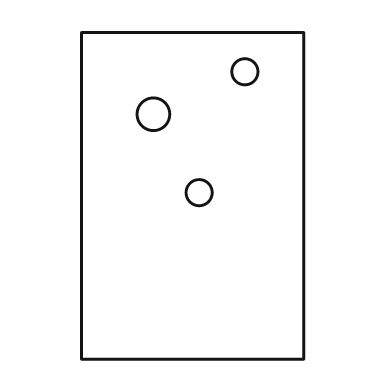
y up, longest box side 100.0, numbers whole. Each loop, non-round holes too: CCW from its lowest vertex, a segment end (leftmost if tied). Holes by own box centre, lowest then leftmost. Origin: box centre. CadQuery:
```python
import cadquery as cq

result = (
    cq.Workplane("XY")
    .moveTo(-34.0, -50.0)
    .lineTo(34.0, -50.0)
    .lineTo(34.0, 50.0)
    .lineTo(-34.0, 50.0)
    .close()
    .moveTo(2.0, 1.0)
    .circle(4.0)
    .moveTo(-12.0, 25.0)
    .circle(5.0)
    .moveTo(16.0, 38.0)
    .circle(4.0)
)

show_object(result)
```